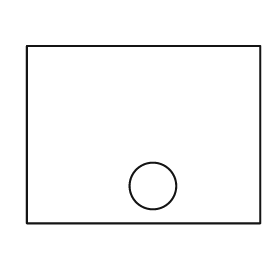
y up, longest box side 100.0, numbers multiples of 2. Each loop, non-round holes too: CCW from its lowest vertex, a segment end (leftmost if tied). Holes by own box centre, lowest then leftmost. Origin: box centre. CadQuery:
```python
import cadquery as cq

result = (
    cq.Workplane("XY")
    .moveTo(-50.0, -38.0)
    .lineTo(50.0, -38.0)
    .lineTo(50.0, 38.0)
    .lineTo(-50.0, 38.0)
    .close()
    .moveTo(4.0, -22.0)
    .circle(10.0)
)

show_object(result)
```